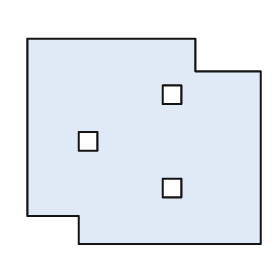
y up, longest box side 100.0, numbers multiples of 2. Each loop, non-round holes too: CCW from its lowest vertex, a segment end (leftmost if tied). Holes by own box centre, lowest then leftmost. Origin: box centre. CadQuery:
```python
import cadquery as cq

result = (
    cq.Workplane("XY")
    .moveTo(-28.0, -44.0)
    .lineTo(50.0, -44.0)
    .lineTo(50.0, 30.0)
    .lineTo(22.0, 30.0)
    .lineTo(22.0, 44.0)
    .lineTo(-50.0, 44.0)
    .lineTo(-50.0, -32.0)
    .lineTo(-28.0, -32.0)
    .close()
    .moveTo(8.0, -24.0)
    .lineTo(16.0, -24.0)
    .lineTo(16.0, -16.0)
    .lineTo(8.0, -16.0)
    .close()
    .moveTo(-28.0, -4.0)
    .lineTo(-20.0, -4.0)
    .lineTo(-20.0, 4.0)
    .lineTo(-28.0, 4.0)
    .close()
    .moveTo(8.0, 16.0)
    .lineTo(16.0, 16.0)
    .lineTo(16.0, 24.0)
    .lineTo(8.0, 24.0)
    .close()
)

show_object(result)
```